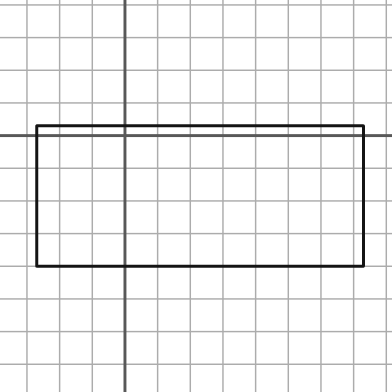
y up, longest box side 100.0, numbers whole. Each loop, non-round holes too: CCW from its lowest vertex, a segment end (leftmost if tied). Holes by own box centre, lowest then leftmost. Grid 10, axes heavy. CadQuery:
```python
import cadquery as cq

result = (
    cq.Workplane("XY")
    .moveTo(-27.0, -40.0)
    .lineTo(73.0, -40.0)
    .lineTo(73.0, 3.0)
    .lineTo(-27.0, 3.0)
    .close()
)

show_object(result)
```